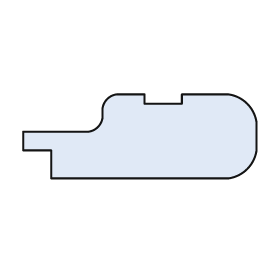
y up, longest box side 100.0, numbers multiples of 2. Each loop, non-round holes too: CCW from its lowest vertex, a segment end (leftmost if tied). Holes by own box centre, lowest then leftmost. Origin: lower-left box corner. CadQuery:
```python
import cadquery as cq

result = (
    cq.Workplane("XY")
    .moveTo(12.0, 0.0)
    .lineTo(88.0, 0.0)
    .threePointArc((96.0, 4.0), (100.0, 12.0))
    .lineTo(100.0, 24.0)
    .threePointArc((96.0, 32.0), (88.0, 36.0))
    .lineTo(68.0, 36.0)
    .lineTo(68.0, 32.0)
    .lineTo(52.0, 32.0)
    .lineTo(52.0, 36.0)
    .lineTo(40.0, 36.0)
    .threePointArc((36.0, 34.0), (34.0, 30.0))
    .lineTo(34.0, 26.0)
    .threePointArc((32.0, 22.0), (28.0, 20.0))
    .lineTo(0.0, 20.0)
    .lineTo(0.0, 12.0)
    .lineTo(12.0, 12.0)
    .close()
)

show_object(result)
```